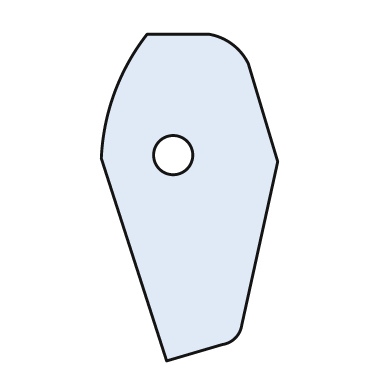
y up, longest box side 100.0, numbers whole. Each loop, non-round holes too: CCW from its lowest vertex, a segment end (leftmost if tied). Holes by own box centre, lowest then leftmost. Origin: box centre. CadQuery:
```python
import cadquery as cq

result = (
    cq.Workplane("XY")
    .moveTo(-7.0, -50.0)
    .lineTo(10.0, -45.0)
    .threePointArc((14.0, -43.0), (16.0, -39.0))
    .lineTo(27.0, 11.0)
    .lineTo(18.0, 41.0)
    .threePointArc((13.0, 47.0), (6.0, 50.0))
    .lineTo(-13.0, 50.0)
    .threePointArc((-23.0, 32.0), (-27.0, 12.0))
    .close()
    .moveTo(-5.0, 13.0)
    .circle(6.0)
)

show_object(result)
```